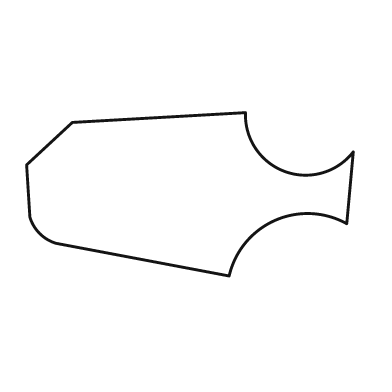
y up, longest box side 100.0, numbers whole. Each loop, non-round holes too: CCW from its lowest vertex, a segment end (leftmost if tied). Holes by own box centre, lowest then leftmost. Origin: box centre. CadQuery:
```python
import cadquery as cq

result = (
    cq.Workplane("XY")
    .moveTo(12.0, -25.0)
    .threePointArc((26.0, -8.0), (48.0, -9.0))
    .lineTo(50.0, 13.0)
    .threePointArc((29.0, 7.0), (17.0, 25.0))
    .lineTo(-36.0, 22.0)
    .lineTo(-50.0, 9.0)
    .lineTo(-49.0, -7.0)
    .threePointArc((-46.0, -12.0), (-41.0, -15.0))
    .close()
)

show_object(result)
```